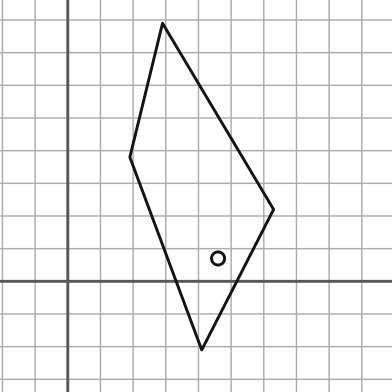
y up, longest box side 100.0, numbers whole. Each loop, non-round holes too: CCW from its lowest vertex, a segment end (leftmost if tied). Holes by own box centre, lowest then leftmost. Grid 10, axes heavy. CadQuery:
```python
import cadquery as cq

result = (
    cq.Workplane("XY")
    .moveTo(41.0, -21.0)
    .lineTo(63.0, 22.0)
    .lineTo(29.0, 79.0)
    .lineTo(19.0, 38.0)
    .close()
    .moveTo(46.0, 7.0)
    .circle(2.0)
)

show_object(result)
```